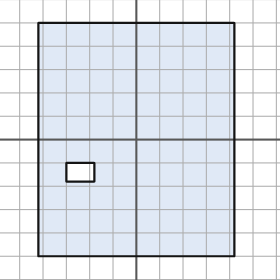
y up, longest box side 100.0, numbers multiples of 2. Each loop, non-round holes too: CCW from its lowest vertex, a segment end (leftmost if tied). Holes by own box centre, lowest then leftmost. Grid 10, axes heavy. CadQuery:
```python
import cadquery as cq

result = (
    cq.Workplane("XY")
    .moveTo(-42.0, -50.0)
    .lineTo(42.0, -50.0)
    .lineTo(42.0, 50.0)
    .lineTo(-42.0, 50.0)
    .close()
    .moveTo(-30.0, -18.0)
    .lineTo(-18.0, -18.0)
    .lineTo(-18.0, -10.0)
    .lineTo(-30.0, -10.0)
    .close()
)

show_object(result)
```